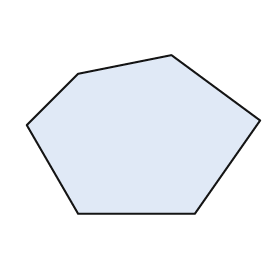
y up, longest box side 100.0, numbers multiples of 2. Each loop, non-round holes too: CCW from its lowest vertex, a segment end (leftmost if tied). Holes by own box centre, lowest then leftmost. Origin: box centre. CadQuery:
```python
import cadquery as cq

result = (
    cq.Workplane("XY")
    .moveTo(-28.0, -34.0)
    .lineTo(22.0, -34.0)
    .lineTo(50.0, 6.0)
    .lineTo(12.0, 34.0)
    .lineTo(-28.0, 26.0)
    .lineTo(-50.0, 4.0)
    .close()
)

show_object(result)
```